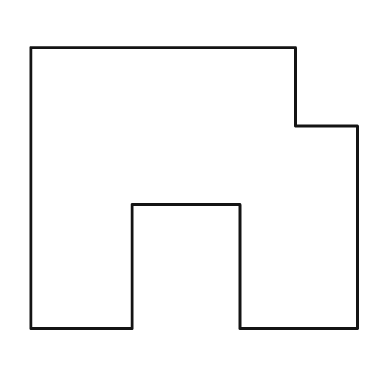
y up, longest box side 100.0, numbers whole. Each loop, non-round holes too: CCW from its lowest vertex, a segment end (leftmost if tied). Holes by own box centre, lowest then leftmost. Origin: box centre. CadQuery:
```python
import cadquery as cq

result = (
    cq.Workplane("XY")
    .moveTo(-50.0, -43.0)
    .lineTo(-19.0, -43.0)
    .lineTo(-19.0, -5.0)
    .lineTo(14.0, -5.0)
    .lineTo(14.0, -43.0)
    .lineTo(50.0, -43.0)
    .lineTo(50.0, 19.0)
    .lineTo(31.0, 19.0)
    .lineTo(31.0, 43.0)
    .lineTo(-50.0, 43.0)
    .close()
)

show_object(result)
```